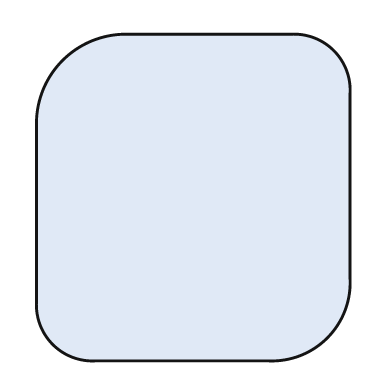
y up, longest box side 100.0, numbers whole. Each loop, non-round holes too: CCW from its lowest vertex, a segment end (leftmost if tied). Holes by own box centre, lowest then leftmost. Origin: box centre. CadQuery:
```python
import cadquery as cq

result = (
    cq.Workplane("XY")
    .moveTo(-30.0, -50.0)
    .lineTo(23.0, -50.0)
    .threePointArc((41.0, -43.0), (48.0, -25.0))
    .lineTo(48.0, 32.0)
    .threePointArc((43.0, 45.0), (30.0, 50.0))
    .lineTo(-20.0, 50.0)
    .threePointArc((-40.0, 42.0), (-48.0, 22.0))
    .lineTo(-48.0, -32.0)
    .threePointArc((-43.0, -45.0), (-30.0, -50.0))
    .close()
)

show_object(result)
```